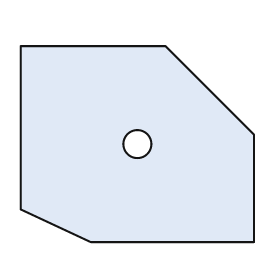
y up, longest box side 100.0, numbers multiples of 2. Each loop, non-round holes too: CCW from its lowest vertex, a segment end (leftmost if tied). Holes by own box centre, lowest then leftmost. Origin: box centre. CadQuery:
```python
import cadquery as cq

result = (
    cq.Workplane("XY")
    .moveTo(-20.0, -42.0)
    .lineTo(50.0, -42.0)
    .lineTo(50.0, 4.0)
    .lineTo(12.0, 42.0)
    .lineTo(-50.0, 42.0)
    .lineTo(-50.0, -28.0)
    .close()
    .moveTo(0.0, 0.0)
    .circle(6.0)
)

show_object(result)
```